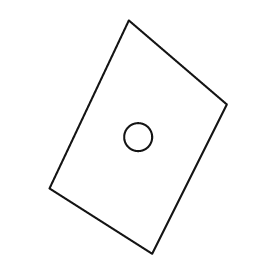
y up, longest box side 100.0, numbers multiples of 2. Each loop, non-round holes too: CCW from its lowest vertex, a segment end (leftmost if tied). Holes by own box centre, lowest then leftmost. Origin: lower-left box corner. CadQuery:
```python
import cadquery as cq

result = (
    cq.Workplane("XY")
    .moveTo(44.0, 0.0)
    .lineTo(76.0, 64.0)
    .lineTo(34.0, 100.0)
    .lineTo(0.0, 28.0)
    .close()
    .moveTo(38.0, 50.0)
    .circle(6.0)
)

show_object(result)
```